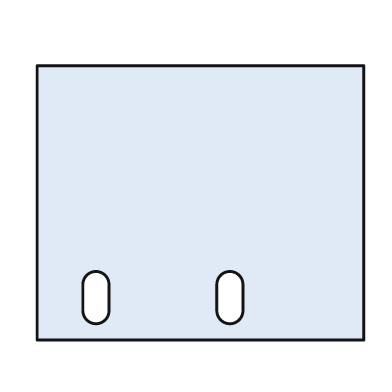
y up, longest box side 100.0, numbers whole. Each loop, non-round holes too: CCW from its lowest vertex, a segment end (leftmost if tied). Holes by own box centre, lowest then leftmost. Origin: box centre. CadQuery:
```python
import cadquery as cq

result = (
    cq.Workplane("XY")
    .moveTo(-50.0, -42.0)
    .lineTo(50.0, -42.0)
    .lineTo(50.0, 42.0)
    .lineTo(-50.0, 42.0)
    .close()
    .moveTo(-36.0, -33.0)
    .threePointArc((-32.0, -37.0), (-28.0, -33.0))
    .lineTo(-28.0, -25.0)
    .threePointArc((-32.0, -21.0), (-36.0, -25.0))
    .close()
    .moveTo(5.0, -33.0)
    .threePointArc((9.0, -37.0), (13.0, -33.0))
    .lineTo(13.0, -25.0)
    .threePointArc((9.0, -21.0), (5.0, -25.0))
    .close()
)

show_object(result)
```